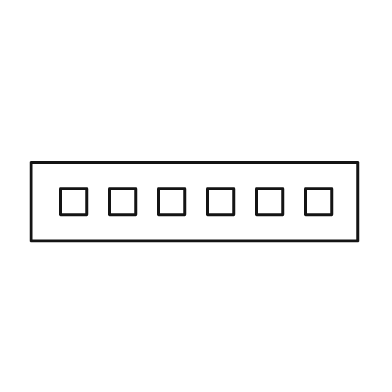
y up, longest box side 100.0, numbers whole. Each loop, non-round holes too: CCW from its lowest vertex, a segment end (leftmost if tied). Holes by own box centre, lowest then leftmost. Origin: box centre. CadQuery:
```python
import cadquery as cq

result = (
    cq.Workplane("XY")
    .moveTo(-50.0, -12.0)
    .lineTo(50.0, -12.0)
    .lineTo(50.0, 12.0)
    .lineTo(-50.0, 12.0)
    .close()
    .moveTo(-41.0, -4.0)
    .lineTo(-33.0, -4.0)
    .lineTo(-33.0, 4.0)
    .lineTo(-41.0, 4.0)
    .close()
    .moveTo(-26.0, -4.0)
    .lineTo(-18.0, -4.0)
    .lineTo(-18.0, 4.0)
    .lineTo(-26.0, 4.0)
    .close()
    .moveTo(-11.0, -4.0)
    .lineTo(-3.0, -4.0)
    .lineTo(-3.0, 4.0)
    .lineTo(-11.0, 4.0)
    .close()
    .moveTo(4.0, -4.0)
    .lineTo(12.0, -4.0)
    .lineTo(12.0, 4.0)
    .lineTo(4.0, 4.0)
    .close()
    .moveTo(19.0, -4.0)
    .lineTo(27.0, -4.0)
    .lineTo(27.0, 4.0)
    .lineTo(19.0, 4.0)
    .close()
    .moveTo(34.0, -4.0)
    .lineTo(42.0, -4.0)
    .lineTo(42.0, 4.0)
    .lineTo(34.0, 4.0)
    .close()
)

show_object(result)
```